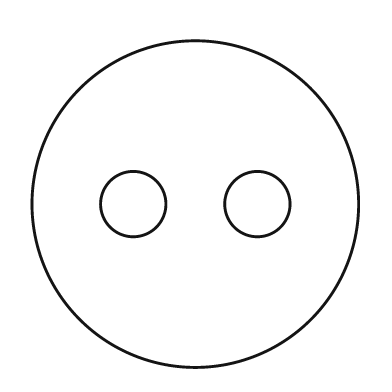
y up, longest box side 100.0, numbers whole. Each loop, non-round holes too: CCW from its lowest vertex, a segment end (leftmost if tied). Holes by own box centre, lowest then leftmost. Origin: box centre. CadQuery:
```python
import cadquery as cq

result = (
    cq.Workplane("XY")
    .moveTo(0.0, 0.0)
    .circle(50.0)
    .moveTo(-19.0, 0.0)
    .circle(10.0)
    .moveTo(19.0, 0.0)
    .circle(10.0)
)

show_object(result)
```